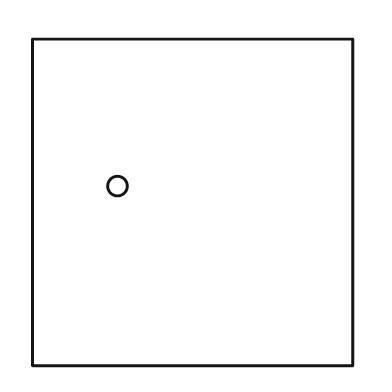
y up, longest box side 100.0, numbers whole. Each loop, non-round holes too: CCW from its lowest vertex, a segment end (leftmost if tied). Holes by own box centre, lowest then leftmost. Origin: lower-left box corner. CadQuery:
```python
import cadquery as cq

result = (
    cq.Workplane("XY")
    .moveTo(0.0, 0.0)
    .lineTo(98.0, 0.0)
    .lineTo(98.0, 100.0)
    .lineTo(0.0, 100.0)
    .close()
    .moveTo(26.0, 55.0)
    .circle(3.0)
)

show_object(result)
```